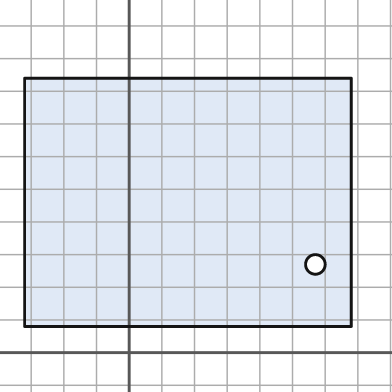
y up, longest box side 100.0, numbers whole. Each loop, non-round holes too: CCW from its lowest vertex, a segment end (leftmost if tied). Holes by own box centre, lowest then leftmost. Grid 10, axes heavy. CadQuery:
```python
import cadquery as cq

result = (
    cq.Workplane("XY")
    .moveTo(-32.0, 8.0)
    .lineTo(68.0, 8.0)
    .lineTo(68.0, 84.0)
    .lineTo(-32.0, 84.0)
    .close()
    .moveTo(57.0, 27.0)
    .circle(3.0)
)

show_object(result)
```